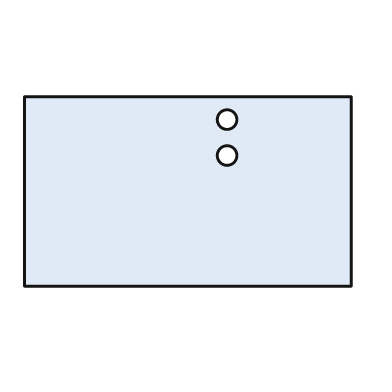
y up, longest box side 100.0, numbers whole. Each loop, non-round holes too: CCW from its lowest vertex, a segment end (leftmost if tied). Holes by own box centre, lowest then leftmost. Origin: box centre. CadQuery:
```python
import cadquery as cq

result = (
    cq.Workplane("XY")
    .moveTo(-50.0, -29.0)
    .lineTo(50.0, -29.0)
    .lineTo(50.0, 29.0)
    .lineTo(-50.0, 29.0)
    .close()
    .moveTo(12.0, 11.0)
    .circle(3.0)
    .moveTo(12.0, 22.0)
    .circle(3.0)
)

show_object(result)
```